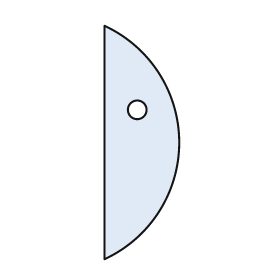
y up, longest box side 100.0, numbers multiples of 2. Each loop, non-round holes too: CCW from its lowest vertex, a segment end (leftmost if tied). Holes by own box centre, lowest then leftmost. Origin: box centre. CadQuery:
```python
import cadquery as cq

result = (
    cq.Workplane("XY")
    .moveTo(-16.0, -50.0)
    .threePointArc((16.0, 0.0), (-16.0, 50.0))
    .close()
    .moveTo(-2.0, 14.0)
    .circle(4.0)
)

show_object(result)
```